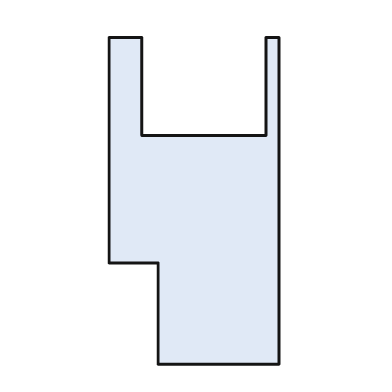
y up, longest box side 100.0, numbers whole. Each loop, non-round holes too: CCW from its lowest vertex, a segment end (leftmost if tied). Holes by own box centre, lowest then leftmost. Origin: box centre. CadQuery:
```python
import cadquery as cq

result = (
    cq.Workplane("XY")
    .moveTo(-11.0, -50.0)
    .lineTo(26.0, -50.0)
    .lineTo(26.0, 50.0)
    .lineTo(22.0, 50.0)
    .lineTo(22.0, 20.0)
    .lineTo(-16.0, 20.0)
    .lineTo(-16.0, 50.0)
    .lineTo(-26.0, 50.0)
    .lineTo(-26.0, -19.0)
    .lineTo(-11.0, -19.0)
    .close()
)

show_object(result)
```